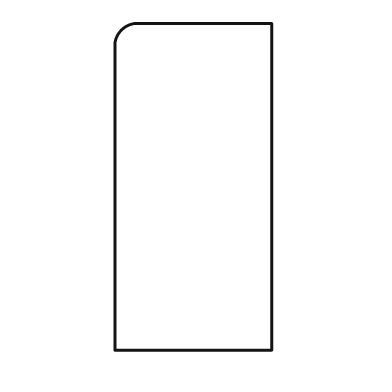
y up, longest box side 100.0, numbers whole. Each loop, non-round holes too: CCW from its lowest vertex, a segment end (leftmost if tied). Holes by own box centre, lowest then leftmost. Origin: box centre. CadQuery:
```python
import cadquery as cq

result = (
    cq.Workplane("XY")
    .moveTo(-24.0, -50.0)
    .lineTo(24.0, -50.0)
    .lineTo(24.0, 50.0)
    .lineTo(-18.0, 50.0)
    .threePointArc((-22.0, 48.0), (-24.0, 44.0))
    .close()
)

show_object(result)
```